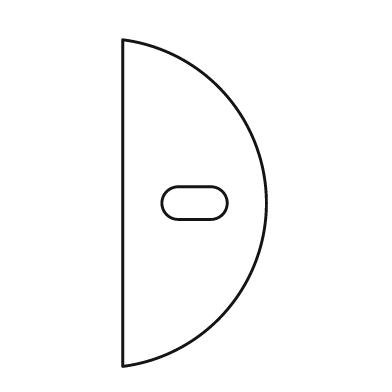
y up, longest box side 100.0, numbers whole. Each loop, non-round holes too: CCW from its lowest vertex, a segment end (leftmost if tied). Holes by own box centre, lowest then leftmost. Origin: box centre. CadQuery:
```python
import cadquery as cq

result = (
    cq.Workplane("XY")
    .moveTo(-22.0, -50.0)
    .threePointArc((22.0, 0.0), (-22.0, 50.0))
    .close()
    .moveTo(-5.0, -5.0)
    .lineTo(5.0, -5.0)
    .threePointArc((10.0, 0.0), (5.0, 5.0))
    .lineTo(-5.0, 5.0)
    .threePointArc((-10.0, 0.0), (-5.0, -5.0))
    .close()
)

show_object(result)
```